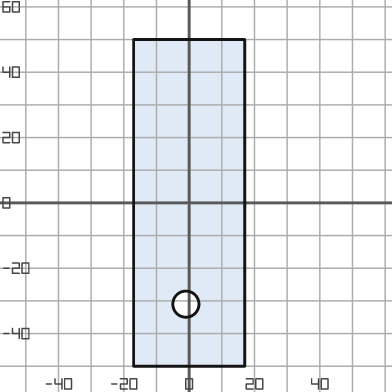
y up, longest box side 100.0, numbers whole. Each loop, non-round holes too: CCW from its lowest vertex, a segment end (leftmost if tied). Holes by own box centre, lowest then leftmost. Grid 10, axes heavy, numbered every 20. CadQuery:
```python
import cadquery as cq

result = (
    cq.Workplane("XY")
    .moveTo(-17.0, -50.0)
    .lineTo(17.0, -50.0)
    .lineTo(17.0, 50.0)
    .lineTo(-17.0, 50.0)
    .close()
    .moveTo(-1.0, -31.0)
    .circle(4.0)
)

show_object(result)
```